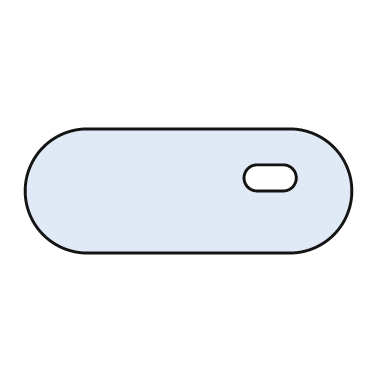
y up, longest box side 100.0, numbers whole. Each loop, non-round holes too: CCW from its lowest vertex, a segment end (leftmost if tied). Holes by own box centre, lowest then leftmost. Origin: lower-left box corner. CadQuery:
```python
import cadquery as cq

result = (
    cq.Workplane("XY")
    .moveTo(19.0, 0.0)
    .lineTo(81.0, 0.0)
    .threePointArc((100.0, 19.0), (81.0, 38.0))
    .lineTo(19.0, 38.0)
    .threePointArc((0.0, 19.0), (19.0, 0.0))
    .close()
    .moveTo(71.0, 19.0)
    .lineTo(79.0, 19.0)
    .threePointArc((83.0, 23.0), (79.0, 27.0))
    .lineTo(71.0, 27.0)
    .threePointArc((67.0, 23.0), (71.0, 19.0))
    .close()
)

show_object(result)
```